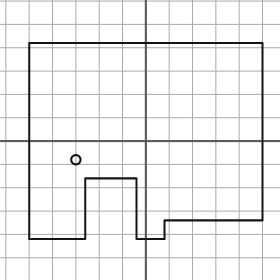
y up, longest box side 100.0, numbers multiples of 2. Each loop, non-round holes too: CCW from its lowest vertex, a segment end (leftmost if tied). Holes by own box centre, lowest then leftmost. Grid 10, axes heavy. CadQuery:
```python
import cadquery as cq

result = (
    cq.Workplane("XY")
    .moveTo(-50.0, -42.0)
    .lineTo(-26.0, -42.0)
    .lineTo(-26.0, -16.0)
    .lineTo(-4.0, -16.0)
    .lineTo(-4.0, -42.0)
    .lineTo(8.0, -42.0)
    .lineTo(8.0, -34.0)
    .lineTo(50.0, -34.0)
    .lineTo(50.0, 42.0)
    .lineTo(-50.0, 42.0)
    .close()
    .moveTo(-30.0, -8.0)
    .circle(2.0)
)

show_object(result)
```